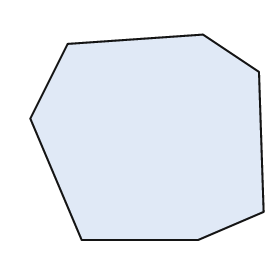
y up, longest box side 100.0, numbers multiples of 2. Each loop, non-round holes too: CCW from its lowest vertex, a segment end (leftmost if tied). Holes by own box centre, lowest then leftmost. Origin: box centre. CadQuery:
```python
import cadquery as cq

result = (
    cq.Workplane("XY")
    .moveTo(-28.0, -44.0)
    .lineTo(22.0, -44.0)
    .lineTo(50.0, -32.0)
    .lineTo(48.0, 28.0)
    .lineTo(24.0, 44.0)
    .lineTo(-34.0, 40.0)
    .lineTo(-50.0, 8.0)
    .close()
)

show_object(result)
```